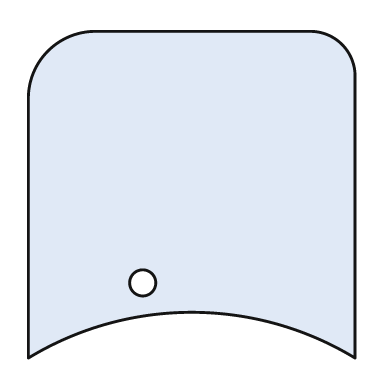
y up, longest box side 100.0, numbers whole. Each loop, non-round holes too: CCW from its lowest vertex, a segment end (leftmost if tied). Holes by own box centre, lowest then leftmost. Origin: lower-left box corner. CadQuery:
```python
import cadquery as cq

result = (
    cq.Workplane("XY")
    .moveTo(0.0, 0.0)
    .threePointArc((50.0, 14.0), (100.0, 0.0))
    .lineTo(100.0, 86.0)
    .threePointArc((96.0, 96.0), (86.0, 100.0))
    .lineTo(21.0, 100.0)
    .threePointArc((6.0, 94.0), (0.0, 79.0))
    .close()
    .moveTo(35.0, 23.0)
    .circle(4.0)
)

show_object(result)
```